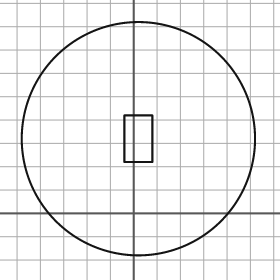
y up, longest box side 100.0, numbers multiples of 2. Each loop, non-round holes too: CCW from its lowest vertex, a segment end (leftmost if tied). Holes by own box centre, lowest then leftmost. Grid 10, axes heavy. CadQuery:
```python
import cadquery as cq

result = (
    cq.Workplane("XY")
    .moveTo(2.0, 32.0)
    .circle(50.0)
    .moveTo(-4.0, 22.0)
    .lineTo(8.0, 22.0)
    .lineTo(8.0, 42.0)
    .lineTo(-4.0, 42.0)
    .close()
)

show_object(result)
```